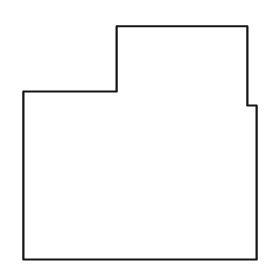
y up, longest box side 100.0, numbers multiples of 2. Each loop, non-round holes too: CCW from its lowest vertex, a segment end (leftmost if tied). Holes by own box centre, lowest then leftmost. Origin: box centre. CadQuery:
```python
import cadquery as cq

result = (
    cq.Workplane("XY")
    .moveTo(-50.0, -50.0)
    .lineTo(50.0, -50.0)
    .lineTo(50.0, 16.0)
    .lineTo(46.0, 16.0)
    .lineTo(46.0, 50.0)
    .lineTo(-10.0, 50.0)
    .lineTo(-10.0, 22.0)
    .lineTo(-50.0, 22.0)
    .close()
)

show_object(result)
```